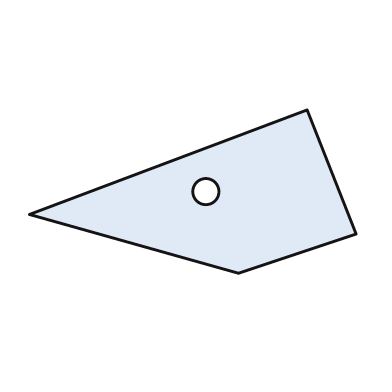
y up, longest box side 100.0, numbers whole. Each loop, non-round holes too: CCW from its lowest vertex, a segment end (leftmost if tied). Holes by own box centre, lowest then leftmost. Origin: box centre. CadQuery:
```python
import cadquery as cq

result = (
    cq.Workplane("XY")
    .moveTo(14.0, -25.0)
    .lineTo(50.0, -13.0)
    .lineTo(35.0, 25.0)
    .lineTo(-50.0, -7.0)
    .close()
    .moveTo(4.0, 0.0)
    .circle(4.0)
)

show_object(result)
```